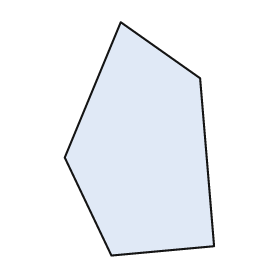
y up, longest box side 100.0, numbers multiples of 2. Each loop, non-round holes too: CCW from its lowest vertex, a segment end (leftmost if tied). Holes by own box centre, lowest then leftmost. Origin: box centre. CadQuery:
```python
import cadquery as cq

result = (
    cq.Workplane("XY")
    .moveTo(-12.0, -50.0)
    .lineTo(32.0, -46.0)
    .lineTo(26.0, 26.0)
    .lineTo(-8.0, 50.0)
    .lineTo(-32.0, -8.0)
    .close()
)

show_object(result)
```